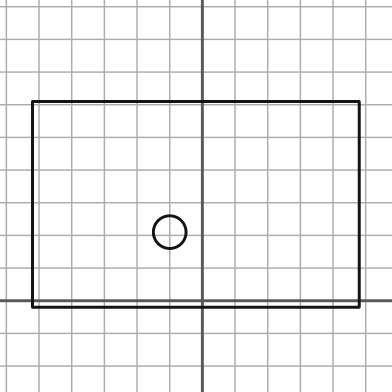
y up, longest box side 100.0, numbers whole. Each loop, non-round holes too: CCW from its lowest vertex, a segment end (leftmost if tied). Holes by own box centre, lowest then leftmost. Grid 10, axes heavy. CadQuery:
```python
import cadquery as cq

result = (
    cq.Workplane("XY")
    .moveTo(-52.0, -2.0)
    .lineTo(48.0, -2.0)
    .lineTo(48.0, 61.0)
    .lineTo(-52.0, 61.0)
    .close()
    .moveTo(-10.0, 21.0)
    .circle(5.0)
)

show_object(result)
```